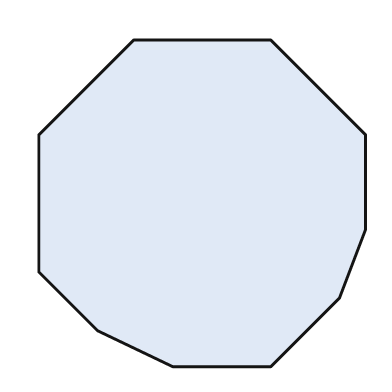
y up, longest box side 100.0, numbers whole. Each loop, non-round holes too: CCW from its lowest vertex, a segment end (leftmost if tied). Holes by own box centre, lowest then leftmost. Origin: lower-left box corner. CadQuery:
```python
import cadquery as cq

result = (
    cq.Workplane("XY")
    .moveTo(41.0, 0.0)
    .lineTo(71.0, 0.0)
    .lineTo(92.0, 21.0)
    .lineTo(100.0, 42.0)
    .lineTo(100.0, 71.0)
    .lineTo(71.0, 100.0)
    .lineTo(29.0, 100.0)
    .lineTo(0.0, 71.0)
    .lineTo(0.0, 29.0)
    .lineTo(18.0, 11.0)
    .close()
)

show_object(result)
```